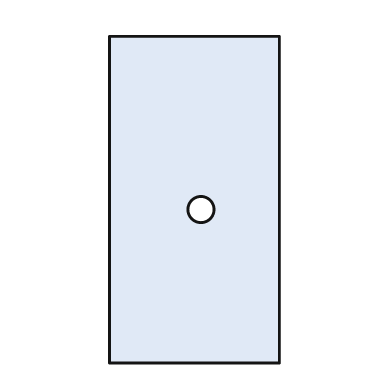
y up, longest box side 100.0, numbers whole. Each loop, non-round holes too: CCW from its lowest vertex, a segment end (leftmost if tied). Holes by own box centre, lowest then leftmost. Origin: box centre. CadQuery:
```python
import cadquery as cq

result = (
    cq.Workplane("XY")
    .moveTo(-26.0, -50.0)
    .lineTo(26.0, -50.0)
    .lineTo(26.0, 50.0)
    .lineTo(-26.0, 50.0)
    .close()
    .moveTo(2.0, -3.0)
    .circle(4.0)
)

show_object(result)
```